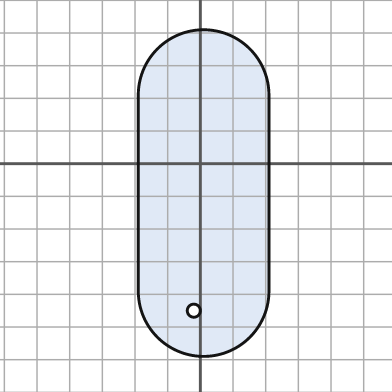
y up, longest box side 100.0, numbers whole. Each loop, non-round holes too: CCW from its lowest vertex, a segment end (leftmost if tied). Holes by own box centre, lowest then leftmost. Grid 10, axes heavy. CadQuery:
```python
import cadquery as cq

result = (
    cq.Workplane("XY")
    .moveTo(-19.0, -39.0)
    .threePointArc((1.0, -59.0), (21.0, -39.0))
    .lineTo(21.0, 21.0)
    .threePointArc((1.0, 41.0), (-19.0, 21.0))
    .close()
    .moveTo(-2.0, -45.0)
    .circle(2.0)
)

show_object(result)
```